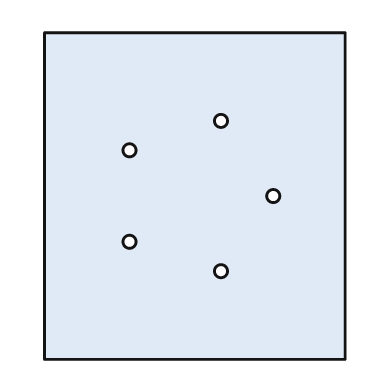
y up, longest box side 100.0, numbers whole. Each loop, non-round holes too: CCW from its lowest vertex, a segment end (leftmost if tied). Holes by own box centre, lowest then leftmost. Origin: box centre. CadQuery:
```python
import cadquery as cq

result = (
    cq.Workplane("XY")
    .moveTo(-46.0, -50.0)
    .lineTo(46.0, -50.0)
    .lineTo(46.0, 50.0)
    .lineTo(-46.0, 50.0)
    .close()
    .moveTo(8.0, -23.0)
    .circle(2.0)
    .moveTo(-20.0, -14.0)
    .circle(2.0)
    .moveTo(24.0, 0.0)
    .circle(2.0)
    .moveTo(-20.0, 14.0)
    .circle(2.0)
    .moveTo(8.0, 23.0)
    .circle(2.0)
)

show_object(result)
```